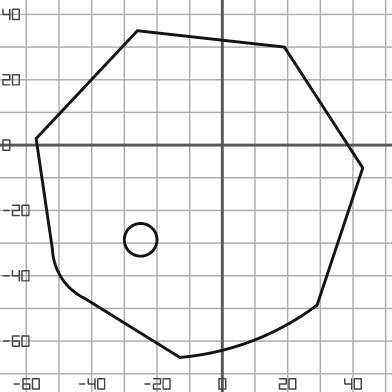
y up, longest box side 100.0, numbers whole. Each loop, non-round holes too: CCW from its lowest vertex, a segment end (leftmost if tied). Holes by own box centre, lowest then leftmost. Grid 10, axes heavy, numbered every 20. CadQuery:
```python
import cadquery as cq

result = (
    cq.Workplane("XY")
    .moveTo(-13.0, -65.0)
    .threePointArc((9.0, -60.0), (29.0, -49.0))
    .lineTo(43.0, -7.0)
    .lineTo(19.0, 30.0)
    .lineTo(-26.0, 35.0)
    .lineTo(-57.0, 2.0)
    .lineTo(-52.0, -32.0)
    .threePointArc((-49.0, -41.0), (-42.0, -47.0))
    .close()
    .moveTo(-25.0, -29.0)
    .circle(5.0)
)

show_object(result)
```